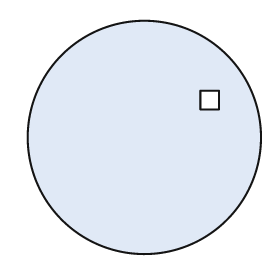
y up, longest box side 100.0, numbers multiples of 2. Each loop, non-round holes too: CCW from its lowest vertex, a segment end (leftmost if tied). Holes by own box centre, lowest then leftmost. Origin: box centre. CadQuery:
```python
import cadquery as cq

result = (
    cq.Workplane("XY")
    .moveTo(0.0, 0.0)
    .circle(50.0)
    .moveTo(24.0, 12.0)
    .lineTo(32.0, 12.0)
    .lineTo(32.0, 20.0)
    .lineTo(24.0, 20.0)
    .close()
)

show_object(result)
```